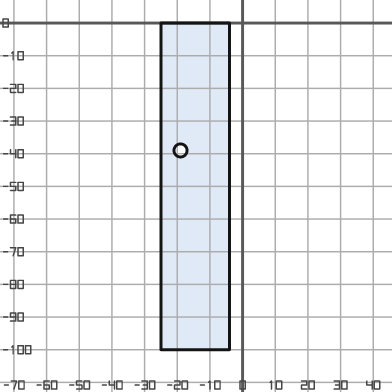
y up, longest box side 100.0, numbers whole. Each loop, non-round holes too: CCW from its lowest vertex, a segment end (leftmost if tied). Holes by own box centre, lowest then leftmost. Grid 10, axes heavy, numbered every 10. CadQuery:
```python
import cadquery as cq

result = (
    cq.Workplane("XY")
    .moveTo(-25.0, -100.0)
    .lineTo(-4.0, -100.0)
    .lineTo(-4.0, 0.0)
    .lineTo(-25.0, 0.0)
    .close()
    .moveTo(-19.0, -39.0)
    .circle(2.0)
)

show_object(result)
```